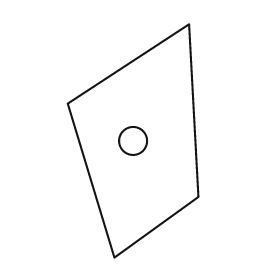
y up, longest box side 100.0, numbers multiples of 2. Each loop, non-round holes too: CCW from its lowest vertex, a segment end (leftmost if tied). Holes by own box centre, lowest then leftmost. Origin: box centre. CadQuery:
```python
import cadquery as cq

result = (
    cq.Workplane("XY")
    .moveTo(-8.0, -50.0)
    .lineTo(28.0, -24.0)
    .lineTo(24.0, 50.0)
    .lineTo(-28.0, 16.0)
    .close()
    .moveTo(0.0, 0.0)
    .circle(6.0)
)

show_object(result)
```